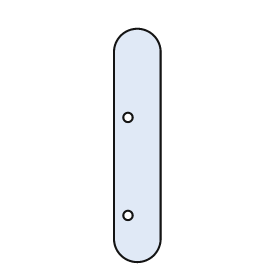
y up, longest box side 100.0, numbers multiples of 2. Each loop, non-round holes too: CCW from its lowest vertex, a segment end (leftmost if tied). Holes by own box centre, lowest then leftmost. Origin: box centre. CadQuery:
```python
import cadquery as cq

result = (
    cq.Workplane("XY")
    .moveTo(-10.0, -40.0)
    .threePointArc((0.0, -50.0), (10.0, -40.0))
    .lineTo(10.0, 40.0)
    .threePointArc((0.0, 50.0), (-10.0, 40.0))
    .close()
    .moveTo(-4.0, -30.0)
    .circle(2.0)
    .moveTo(-4.0, 12.0)
    .circle(2.0)
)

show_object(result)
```